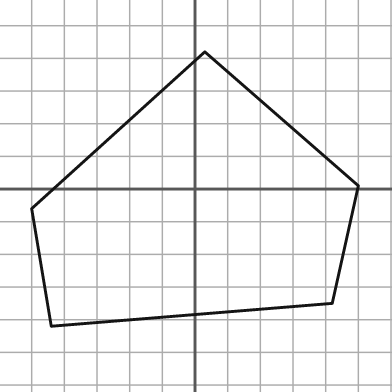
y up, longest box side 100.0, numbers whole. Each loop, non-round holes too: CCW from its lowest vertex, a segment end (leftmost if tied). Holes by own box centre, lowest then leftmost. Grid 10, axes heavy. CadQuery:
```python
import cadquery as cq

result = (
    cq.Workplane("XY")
    .moveTo(-44.0, -42.0)
    .lineTo(42.0, -35.0)
    .lineTo(50.0, 1.0)
    .lineTo(3.0, 42.0)
    .lineTo(-50.0, -6.0)
    .close()
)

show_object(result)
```